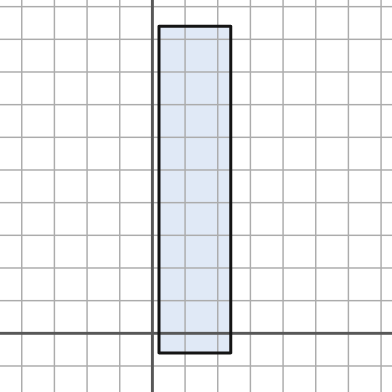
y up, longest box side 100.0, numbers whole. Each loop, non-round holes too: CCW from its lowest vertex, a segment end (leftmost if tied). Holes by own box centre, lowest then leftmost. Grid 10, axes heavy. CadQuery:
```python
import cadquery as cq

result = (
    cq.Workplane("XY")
    .moveTo(2.0, -6.0)
    .lineTo(24.0, -6.0)
    .lineTo(24.0, 94.0)
    .lineTo(2.0, 94.0)
    .close()
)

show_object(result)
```